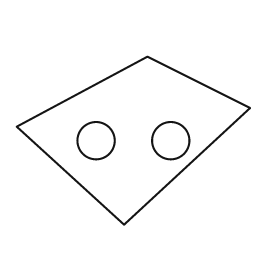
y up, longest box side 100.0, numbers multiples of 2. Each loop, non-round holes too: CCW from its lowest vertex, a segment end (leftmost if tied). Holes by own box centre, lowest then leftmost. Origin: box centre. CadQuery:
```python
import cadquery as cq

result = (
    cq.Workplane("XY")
    .moveTo(-4.0, -36.0)
    .lineTo(50.0, 14.0)
    .lineTo(6.0, 36.0)
    .lineTo(-50.0, 6.0)
    .close()
    .moveTo(-16.0, 0.0)
    .circle(8.0)
    .moveTo(16.0, 0.0)
    .circle(8.0)
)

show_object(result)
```